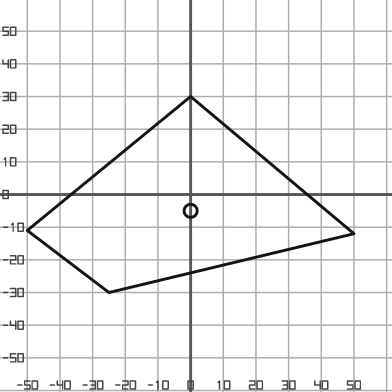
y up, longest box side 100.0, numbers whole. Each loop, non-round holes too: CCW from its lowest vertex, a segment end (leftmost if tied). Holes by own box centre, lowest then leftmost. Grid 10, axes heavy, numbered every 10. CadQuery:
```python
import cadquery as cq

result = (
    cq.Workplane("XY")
    .moveTo(-25.0, -30.0)
    .lineTo(50.0, -12.0)
    .lineTo(0.0, 30.0)
    .lineTo(-50.0, -11.0)
    .close()
    .moveTo(0.0, -5.0)
    .circle(2.0)
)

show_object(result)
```